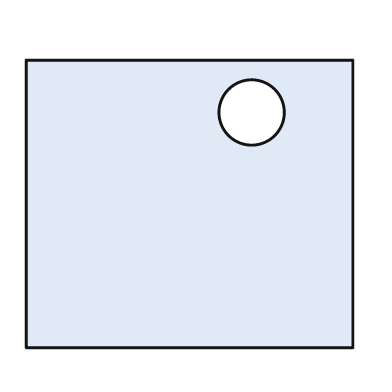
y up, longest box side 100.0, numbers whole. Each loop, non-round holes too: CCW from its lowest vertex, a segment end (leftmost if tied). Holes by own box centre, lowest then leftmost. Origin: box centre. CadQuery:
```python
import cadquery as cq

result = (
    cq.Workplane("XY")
    .moveTo(-50.0, -44.0)
    .lineTo(50.0, -44.0)
    .lineTo(50.0, 44.0)
    .lineTo(-50.0, 44.0)
    .close()
    .moveTo(19.0, 28.0)
    .circle(10.0)
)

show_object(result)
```